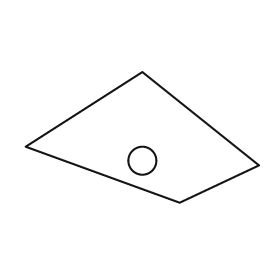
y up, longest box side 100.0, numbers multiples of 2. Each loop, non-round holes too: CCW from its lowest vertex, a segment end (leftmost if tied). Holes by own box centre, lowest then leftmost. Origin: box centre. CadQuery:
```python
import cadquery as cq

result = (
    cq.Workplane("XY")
    .moveTo(16.0, -28.0)
    .lineTo(50.0, -12.0)
    .lineTo(0.0, 28.0)
    .lineTo(-50.0, -4.0)
    .close()
    .moveTo(0.0, -10.0)
    .circle(6.0)
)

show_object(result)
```